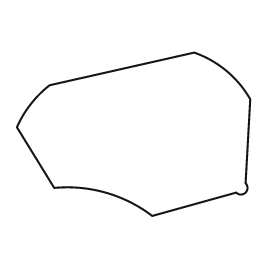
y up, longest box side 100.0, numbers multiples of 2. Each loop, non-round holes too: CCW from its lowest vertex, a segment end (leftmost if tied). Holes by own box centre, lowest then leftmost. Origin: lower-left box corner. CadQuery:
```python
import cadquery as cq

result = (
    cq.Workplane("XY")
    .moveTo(58.0, 0.0)
    .lineTo(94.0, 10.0)
    .threePointArc((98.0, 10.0), (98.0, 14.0))
    .lineTo(100.0, 50.0)
    .threePointArc((90.0, 62.0), (76.0, 70.0))
    .lineTo(14.0, 56.0)
    .threePointArc((6.0, 48.0), (0.0, 38.0))
    .lineTo(16.0, 12.0)
    .threePointArc((38.0, 10.0), (58.0, 0.0))
    .close()
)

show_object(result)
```